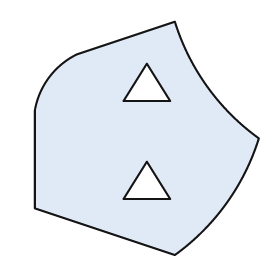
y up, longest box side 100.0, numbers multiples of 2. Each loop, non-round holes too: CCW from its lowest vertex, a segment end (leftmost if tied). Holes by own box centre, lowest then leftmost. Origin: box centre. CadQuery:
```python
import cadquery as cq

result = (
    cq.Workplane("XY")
    .moveTo(12.0, -50.0)
    .threePointArc((34.0, -28.0), (48.0, 0.0))
    .threePointArc((26.0, 22.0), (12.0, 50.0))
    .lineTo(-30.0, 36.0)
    .threePointArc((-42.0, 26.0), (-48.0, 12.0))
    .lineTo(-48.0, -30.0)
    .close()
    .moveTo(-10.0, -26.0)
    .lineTo(10.0, -26.0)
    .lineTo(0.0, -10.0)
    .close()
    .moveTo(-10.0, 16.0)
    .lineTo(10.0, 16.0)
    .lineTo(0.0, 32.0)
    .close()
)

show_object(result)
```